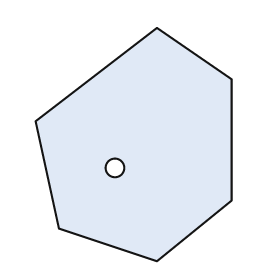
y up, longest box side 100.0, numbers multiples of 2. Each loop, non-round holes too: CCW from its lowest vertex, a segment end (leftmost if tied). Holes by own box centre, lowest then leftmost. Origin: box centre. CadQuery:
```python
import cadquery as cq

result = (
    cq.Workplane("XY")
    .moveTo(10.0, -50.0)
    .lineTo(42.0, -24.0)
    .lineTo(42.0, 28.0)
    .lineTo(10.0, 50.0)
    .lineTo(-42.0, 10.0)
    .lineTo(-32.0, -36.0)
    .close()
    .moveTo(-8.0, -10.0)
    .circle(4.0)
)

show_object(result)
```